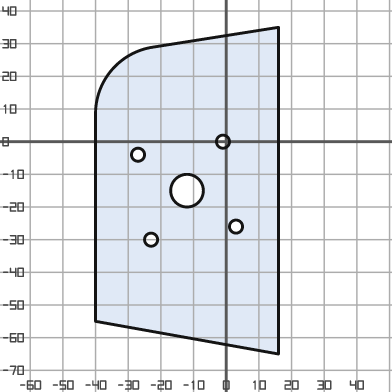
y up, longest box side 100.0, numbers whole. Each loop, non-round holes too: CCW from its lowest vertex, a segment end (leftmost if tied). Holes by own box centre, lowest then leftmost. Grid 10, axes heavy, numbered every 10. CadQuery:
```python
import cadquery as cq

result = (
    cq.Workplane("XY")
    .moveTo(16.0, -65.0)
    .lineTo(16.0, 35.0)
    .lineTo(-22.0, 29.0)
    .threePointArc((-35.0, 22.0), (-40.0, 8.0))
    .lineTo(-40.0, -55.0)
    .close()
    .moveTo(-23.0, -30.0)
    .circle(2.0)
    .moveTo(3.0, -26.0)
    .circle(2.0)
    .moveTo(-12.0, -15.0)
    .circle(5.0)
    .moveTo(-27.0, -4.0)
    .circle(2.0)
    .moveTo(-1.0, 0.0)
    .circle(2.0)
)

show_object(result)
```